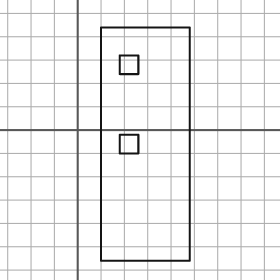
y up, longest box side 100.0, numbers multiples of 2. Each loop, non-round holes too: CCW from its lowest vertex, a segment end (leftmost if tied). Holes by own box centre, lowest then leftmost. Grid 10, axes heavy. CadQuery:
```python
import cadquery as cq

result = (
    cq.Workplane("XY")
    .moveTo(10.0, -56.0)
    .lineTo(48.0, -56.0)
    .lineTo(48.0, 44.0)
    .lineTo(10.0, 44.0)
    .close()
    .moveTo(18.0, -10.0)
    .lineTo(26.0, -10.0)
    .lineTo(26.0, -2.0)
    .lineTo(18.0, -2.0)
    .close()
    .moveTo(18.0, 24.0)
    .lineTo(26.0, 24.0)
    .lineTo(26.0, 32.0)
    .lineTo(18.0, 32.0)
    .close()
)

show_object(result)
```